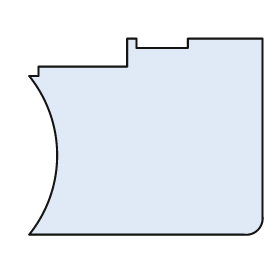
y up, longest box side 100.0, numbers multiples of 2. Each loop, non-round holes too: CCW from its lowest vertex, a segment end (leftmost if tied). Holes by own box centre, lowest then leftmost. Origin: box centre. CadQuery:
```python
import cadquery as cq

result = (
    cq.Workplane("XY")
    .moveTo(-50.0, -42.0)
    .lineTo(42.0, -42.0)
    .threePointArc((48.0, -40.0), (50.0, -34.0))
    .lineTo(50.0, 42.0)
    .lineTo(18.0, 42.0)
    .lineTo(18.0, 38.0)
    .lineTo(-4.0, 38.0)
    .lineTo(-4.0, 42.0)
    .lineTo(-8.0, 42.0)
    .lineTo(-8.0, 30.0)
    .lineTo(-46.0, 30.0)
    .lineTo(-46.0, 26.0)
    .lineTo(-50.0, 26.0)
    .threePointArc((-38.0, -8.0), (-50.0, -42.0))
    .close()
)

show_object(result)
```